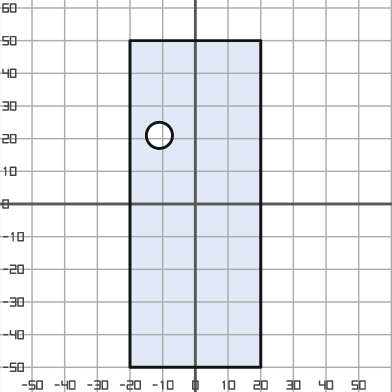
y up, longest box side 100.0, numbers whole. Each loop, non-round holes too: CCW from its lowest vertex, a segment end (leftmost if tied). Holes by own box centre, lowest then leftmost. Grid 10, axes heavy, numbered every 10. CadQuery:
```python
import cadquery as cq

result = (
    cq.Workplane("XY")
    .moveTo(-20.0, -50.0)
    .lineTo(20.0, -50.0)
    .lineTo(20.0, 50.0)
    .lineTo(-20.0, 50.0)
    .close()
    .moveTo(-11.0, 21.0)
    .circle(4.0)
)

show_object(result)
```